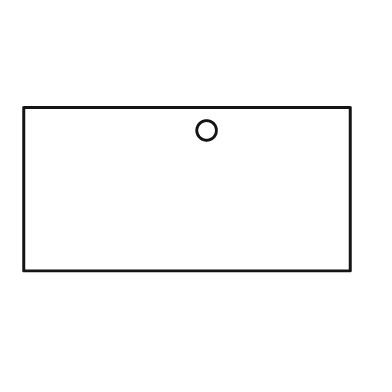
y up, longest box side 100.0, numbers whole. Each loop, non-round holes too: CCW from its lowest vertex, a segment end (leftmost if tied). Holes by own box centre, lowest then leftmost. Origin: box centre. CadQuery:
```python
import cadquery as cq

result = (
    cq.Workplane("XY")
    .moveTo(-50.0, -25.0)
    .lineTo(50.0, -25.0)
    .lineTo(50.0, 25.0)
    .lineTo(-50.0, 25.0)
    .close()
    .moveTo(6.0, 18.0)
    .circle(3.0)
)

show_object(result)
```